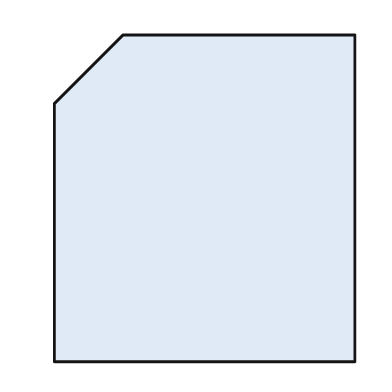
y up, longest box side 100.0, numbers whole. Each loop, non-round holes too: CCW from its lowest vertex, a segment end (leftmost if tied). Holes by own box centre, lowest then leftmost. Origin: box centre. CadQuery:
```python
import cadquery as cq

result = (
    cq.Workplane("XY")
    .moveTo(-46.0, -50.0)
    .lineTo(46.0, -50.0)
    .lineTo(46.0, 50.0)
    .lineTo(-25.0, 50.0)
    .lineTo(-46.0, 29.0)
    .close()
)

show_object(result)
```